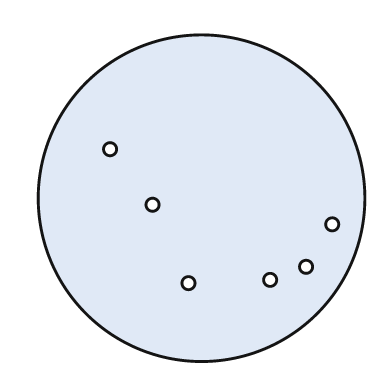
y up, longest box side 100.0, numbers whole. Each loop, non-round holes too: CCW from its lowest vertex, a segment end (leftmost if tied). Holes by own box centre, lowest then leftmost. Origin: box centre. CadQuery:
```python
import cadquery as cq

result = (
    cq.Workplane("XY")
    .moveTo(0.0, 0.0)
    .circle(50.0)
    .moveTo(-4.0, -26.0)
    .circle(2.0)
    .moveTo(21.0, -25.0)
    .circle(2.0)
    .moveTo(32.0, -21.0)
    .circle(2.0)
    .moveTo(40.0, -8.0)
    .circle(2.0)
    .moveTo(-15.0, -2.0)
    .circle(2.0)
    .moveTo(-28.0, 15.0)
    .circle(2.0)
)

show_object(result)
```